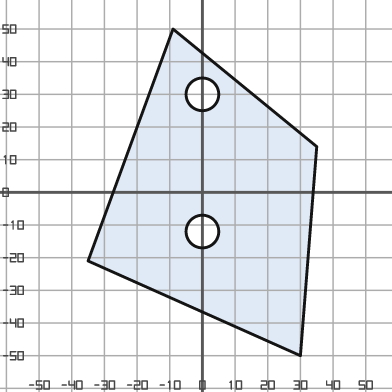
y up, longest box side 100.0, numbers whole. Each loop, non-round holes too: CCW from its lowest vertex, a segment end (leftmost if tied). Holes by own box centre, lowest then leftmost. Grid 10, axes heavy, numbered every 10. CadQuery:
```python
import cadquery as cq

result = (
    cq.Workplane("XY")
    .moveTo(30.0, -50.0)
    .lineTo(35.0, 14.0)
    .lineTo(-9.0, 50.0)
    .lineTo(-35.0, -21.0)
    .close()
    .moveTo(0.0, -12.0)
    .circle(5.0)
    .moveTo(0.0, 30.0)
    .circle(5.0)
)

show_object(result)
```